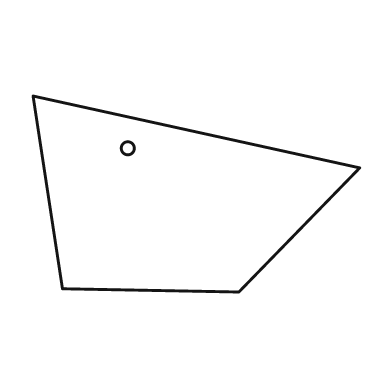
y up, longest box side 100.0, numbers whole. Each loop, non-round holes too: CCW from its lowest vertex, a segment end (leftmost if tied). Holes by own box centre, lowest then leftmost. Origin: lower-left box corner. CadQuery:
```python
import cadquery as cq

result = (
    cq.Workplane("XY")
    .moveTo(63.0, 0.0)
    .lineTo(100.0, 38.0)
    .lineTo(0.0, 60.0)
    .lineTo(9.0, 1.0)
    .close()
    .moveTo(29.0, 44.0)
    .circle(2.0)
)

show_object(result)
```